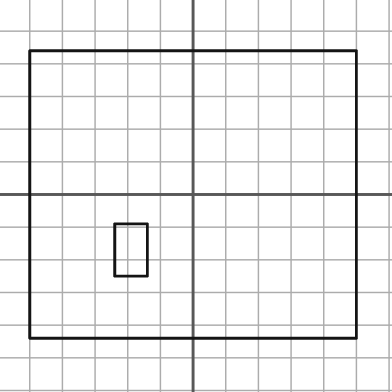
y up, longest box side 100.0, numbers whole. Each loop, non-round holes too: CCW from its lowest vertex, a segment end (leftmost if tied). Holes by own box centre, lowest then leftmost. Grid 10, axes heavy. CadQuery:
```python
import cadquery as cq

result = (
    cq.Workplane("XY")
    .moveTo(-50.0, -44.0)
    .lineTo(50.0, -44.0)
    .lineTo(50.0, 44.0)
    .lineTo(-50.0, 44.0)
    .close()
    .moveTo(-24.0, -25.0)
    .lineTo(-14.0, -25.0)
    .lineTo(-14.0, -9.0)
    .lineTo(-24.0, -9.0)
    .close()
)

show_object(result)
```